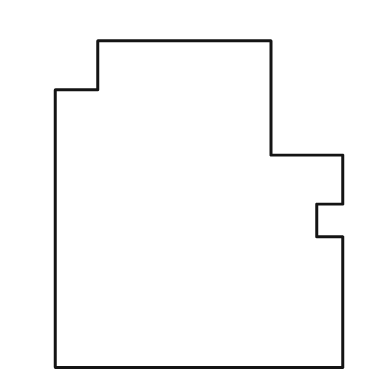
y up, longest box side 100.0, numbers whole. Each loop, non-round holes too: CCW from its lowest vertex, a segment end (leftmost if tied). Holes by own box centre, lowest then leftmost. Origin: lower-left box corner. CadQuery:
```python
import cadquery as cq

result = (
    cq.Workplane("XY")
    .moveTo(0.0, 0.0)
    .lineTo(88.0, 0.0)
    .lineTo(88.0, 40.0)
    .lineTo(80.0, 40.0)
    .lineTo(80.0, 50.0)
    .lineTo(88.0, 50.0)
    .lineTo(88.0, 65.0)
    .lineTo(66.0, 65.0)
    .lineTo(66.0, 100.0)
    .lineTo(13.0, 100.0)
    .lineTo(13.0, 85.0)
    .lineTo(0.0, 85.0)
    .close()
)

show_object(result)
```